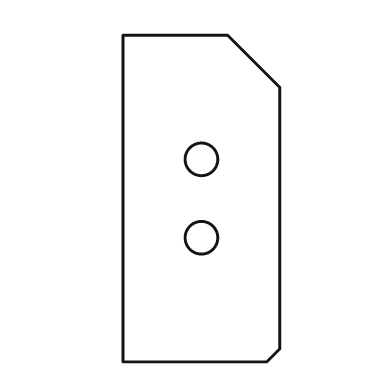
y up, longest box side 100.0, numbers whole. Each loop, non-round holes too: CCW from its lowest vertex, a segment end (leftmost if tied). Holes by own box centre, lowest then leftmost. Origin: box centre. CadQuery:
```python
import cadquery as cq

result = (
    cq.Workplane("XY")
    .moveTo(-24.0, -50.0)
    .lineTo(20.0, -50.0)
    .lineTo(24.0, -46.0)
    .lineTo(24.0, 34.0)
    .lineTo(8.0, 50.0)
    .lineTo(-24.0, 50.0)
    .close()
    .moveTo(0.0, -12.0)
    .circle(5.0)
    .moveTo(0.0, 12.0)
    .circle(5.0)
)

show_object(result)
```